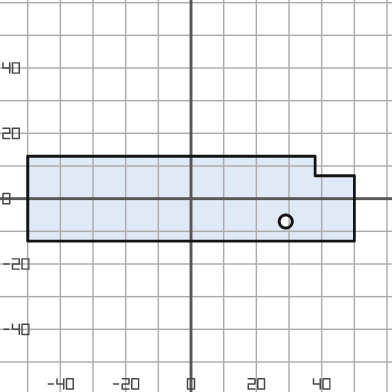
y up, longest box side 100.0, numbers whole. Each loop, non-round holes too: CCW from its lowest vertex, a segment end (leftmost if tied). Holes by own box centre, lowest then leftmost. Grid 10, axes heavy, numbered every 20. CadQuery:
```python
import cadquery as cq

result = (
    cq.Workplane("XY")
    .moveTo(-50.0, -13.0)
    .lineTo(50.0, -13.0)
    .lineTo(50.0, 7.0)
    .lineTo(38.0, 7.0)
    .lineTo(38.0, 13.0)
    .lineTo(-50.0, 13.0)
    .close()
    .moveTo(29.0, -7.0)
    .circle(2.0)
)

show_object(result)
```